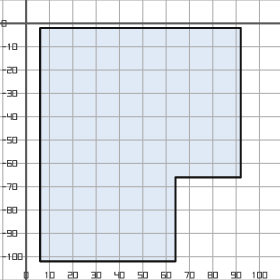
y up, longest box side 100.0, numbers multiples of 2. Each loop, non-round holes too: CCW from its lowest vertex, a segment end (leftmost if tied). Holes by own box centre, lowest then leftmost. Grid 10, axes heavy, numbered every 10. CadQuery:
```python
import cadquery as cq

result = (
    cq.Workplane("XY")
    .moveTo(6.0, -102.0)
    .lineTo(64.0, -102.0)
    .lineTo(64.0, -66.0)
    .lineTo(92.0, -66.0)
    .lineTo(92.0, -2.0)
    .lineTo(6.0, -2.0)
    .close()
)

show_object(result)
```